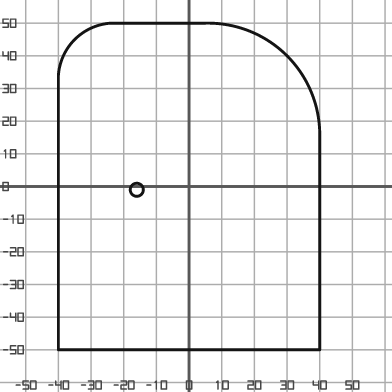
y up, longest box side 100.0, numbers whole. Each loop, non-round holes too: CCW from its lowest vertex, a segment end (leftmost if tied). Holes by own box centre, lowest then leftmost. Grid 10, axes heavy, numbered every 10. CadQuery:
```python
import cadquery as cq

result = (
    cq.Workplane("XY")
    .moveTo(-40.0, -50.0)
    .lineTo(40.0, -50.0)
    .lineTo(40.0, 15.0)
    .threePointArc((30.0, 40.0), (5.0, 50.0))
    .lineTo(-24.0, 50.0)
    .threePointArc((-35.0, 45.0), (-40.0, 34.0))
    .close()
    .moveTo(-16.0, -1.0)
    .circle(2.0)
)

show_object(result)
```